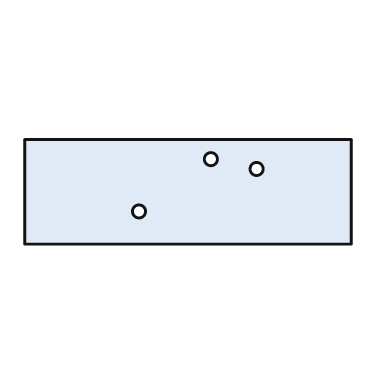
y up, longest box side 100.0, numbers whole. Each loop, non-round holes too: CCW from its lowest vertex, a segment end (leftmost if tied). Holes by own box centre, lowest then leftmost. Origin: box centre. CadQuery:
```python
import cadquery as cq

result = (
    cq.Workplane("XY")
    .moveTo(-50.0, -16.0)
    .lineTo(50.0, -16.0)
    .lineTo(50.0, 16.0)
    .lineTo(-50.0, 16.0)
    .close()
    .moveTo(-15.0, -6.0)
    .circle(2.0)
    .moveTo(21.0, 7.0)
    .circle(2.0)
    .moveTo(7.0, 10.0)
    .circle(2.0)
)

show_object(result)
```